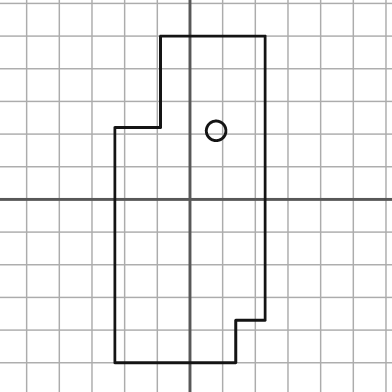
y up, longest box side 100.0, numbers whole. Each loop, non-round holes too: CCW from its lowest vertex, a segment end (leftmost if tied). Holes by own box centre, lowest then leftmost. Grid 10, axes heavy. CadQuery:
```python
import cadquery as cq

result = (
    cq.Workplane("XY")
    .moveTo(-23.0, -50.0)
    .lineTo(14.0, -50.0)
    .lineTo(14.0, -37.0)
    .lineTo(23.0, -37.0)
    .lineTo(23.0, 50.0)
    .lineTo(-9.0, 50.0)
    .lineTo(-9.0, 22.0)
    .lineTo(-23.0, 22.0)
    .close()
    .moveTo(8.0, 21.0)
    .circle(3.0)
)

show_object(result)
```